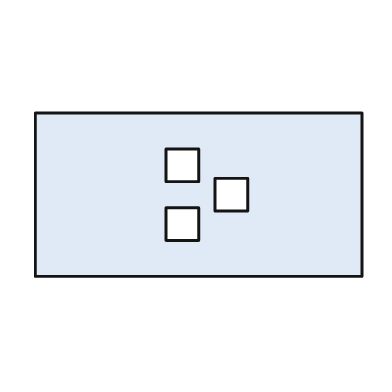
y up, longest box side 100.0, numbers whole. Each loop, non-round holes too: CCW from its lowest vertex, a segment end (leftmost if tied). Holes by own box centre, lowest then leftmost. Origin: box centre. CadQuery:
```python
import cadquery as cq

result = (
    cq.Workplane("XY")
    .moveTo(-50.0, -25.0)
    .lineTo(50.0, -25.0)
    .lineTo(50.0, 25.0)
    .lineTo(-50.0, 25.0)
    .close()
    .moveTo(-10.0, -14.0)
    .lineTo(0.0, -14.0)
    .lineTo(0.0, -4.0)
    .lineTo(-10.0, -4.0)
    .close()
    .moveTo(5.0, -5.0)
    .lineTo(15.0, -5.0)
    .lineTo(15.0, 5.0)
    .lineTo(5.0, 5.0)
    .close()
    .moveTo(-10.0, 4.0)
    .lineTo(0.0, 4.0)
    .lineTo(0.0, 14.0)
    .lineTo(-10.0, 14.0)
    .close()
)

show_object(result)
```